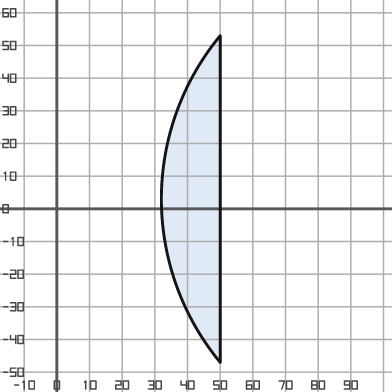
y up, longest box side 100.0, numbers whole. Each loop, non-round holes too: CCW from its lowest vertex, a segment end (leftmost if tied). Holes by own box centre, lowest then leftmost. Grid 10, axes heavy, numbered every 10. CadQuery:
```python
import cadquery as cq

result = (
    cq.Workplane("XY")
    .moveTo(50.0, -47.0)
    .lineTo(50.0, 53.0)
    .threePointArc((32.0, 3.0), (50.0, -47.0))
    .close()
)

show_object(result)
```